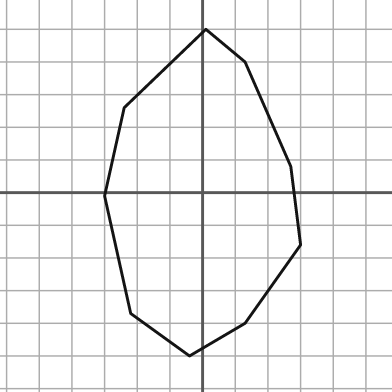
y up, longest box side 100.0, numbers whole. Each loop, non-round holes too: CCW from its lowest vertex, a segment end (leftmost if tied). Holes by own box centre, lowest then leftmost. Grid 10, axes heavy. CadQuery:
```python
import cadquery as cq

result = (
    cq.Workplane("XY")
    .moveTo(-4.0, -50.0)
    .lineTo(13.0, -40.0)
    .lineTo(30.0, -16.0)
    .lineTo(27.0, 8.0)
    .lineTo(13.0, 40.0)
    .lineTo(1.0, 50.0)
    .lineTo(-24.0, 26.0)
    .lineTo(-30.0, -1.0)
    .lineTo(-22.0, -37.0)
    .close()
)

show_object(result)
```